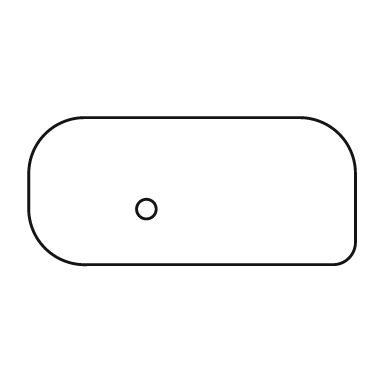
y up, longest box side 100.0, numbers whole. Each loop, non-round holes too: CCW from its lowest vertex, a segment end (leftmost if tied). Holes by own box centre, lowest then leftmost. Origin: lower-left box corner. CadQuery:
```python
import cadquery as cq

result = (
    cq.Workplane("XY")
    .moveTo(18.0, 0.0)
    .lineTo(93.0, 0.0)
    .threePointArc((98.0, 2.0), (100.0, 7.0))
    .lineTo(100.0, 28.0)
    .threePointArc((95.0, 40.0), (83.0, 45.0))
    .lineTo(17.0, 45.0)
    .threePointArc((5.0, 40.0), (0.0, 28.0))
    .lineTo(0.0, 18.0)
    .threePointArc((5.0, 5.0), (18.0, 0.0))
    .close()
    .moveTo(36.0, 17.0)
    .circle(3.0)
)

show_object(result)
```